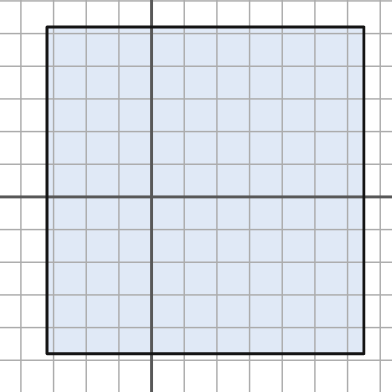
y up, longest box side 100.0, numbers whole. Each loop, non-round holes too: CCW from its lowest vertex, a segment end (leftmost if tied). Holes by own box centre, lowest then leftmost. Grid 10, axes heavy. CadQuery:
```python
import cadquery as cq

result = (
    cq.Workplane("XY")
    .moveTo(-32.0, -48.0)
    .lineTo(65.0, -48.0)
    .lineTo(65.0, 52.0)
    .lineTo(-32.0, 52.0)
    .close()
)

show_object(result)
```